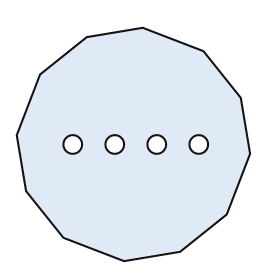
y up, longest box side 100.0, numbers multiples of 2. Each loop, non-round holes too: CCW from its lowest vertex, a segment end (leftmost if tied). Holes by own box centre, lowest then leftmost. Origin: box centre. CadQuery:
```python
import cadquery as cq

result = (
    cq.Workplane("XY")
    .moveTo(-4.0, -50.0)
    .lineTo(20.0, -46.0)
    .lineTo(40.0, -30.0)
    .lineTo(50.0, -4.0)
    .lineTo(46.0, 20.0)
    .lineTo(30.0, 40.0)
    .lineTo(4.0, 50.0)
    .lineTo(-20.0, 46.0)
    .lineTo(-40.0, 30.0)
    .lineTo(-50.0, 4.0)
    .lineTo(-46.0, -20.0)
    .lineTo(-30.0, -40.0)
    .close()
    .moveTo(-26.0, 0.0)
    .circle(4.0)
    .moveTo(-8.0, 0.0)
    .circle(4.0)
    .moveTo(10.0, 0.0)
    .circle(4.0)
    .moveTo(28.0, 0.0)
    .circle(4.0)
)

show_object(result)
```